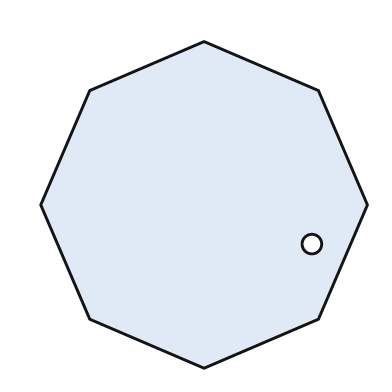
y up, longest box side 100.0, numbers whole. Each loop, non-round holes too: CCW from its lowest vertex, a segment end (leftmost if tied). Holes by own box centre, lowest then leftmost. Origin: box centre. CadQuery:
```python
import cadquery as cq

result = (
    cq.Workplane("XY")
    .moveTo(0.0, -50.0)
    .lineTo(35.0, -35.0)
    .lineTo(50.0, 0.0)
    .lineTo(35.0, 35.0)
    .lineTo(0.0, 50.0)
    .lineTo(-35.0, 35.0)
    .lineTo(-50.0, 0.0)
    .lineTo(-35.0, -35.0)
    .close()
    .moveTo(33.0, -12.0)
    .circle(3.0)
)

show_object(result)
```